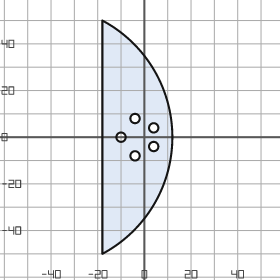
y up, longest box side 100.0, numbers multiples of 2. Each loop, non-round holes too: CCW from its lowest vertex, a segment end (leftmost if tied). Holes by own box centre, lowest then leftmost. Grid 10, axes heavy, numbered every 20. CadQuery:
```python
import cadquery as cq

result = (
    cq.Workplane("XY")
    .moveTo(-18.0, -50.0)
    .threePointArc((12.0, 0.0), (-18.0, 50.0))
    .close()
    .moveTo(-4.0, -8.0)
    .circle(2.0)
    .moveTo(4.0, -4.0)
    .circle(2.0)
    .moveTo(-10.0, 0.0)
    .circle(2.0)
    .moveTo(4.0, 4.0)
    .circle(2.0)
    .moveTo(-4.0, 8.0)
    .circle(2.0)
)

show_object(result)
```